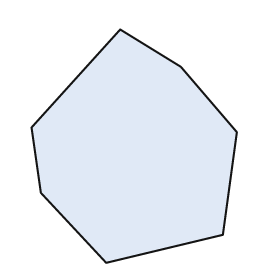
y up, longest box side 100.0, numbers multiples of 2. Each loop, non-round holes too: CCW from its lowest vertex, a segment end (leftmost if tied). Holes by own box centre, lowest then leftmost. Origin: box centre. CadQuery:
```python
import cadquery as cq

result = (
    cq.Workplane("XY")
    .moveTo(-12.0, -50.0)
    .lineTo(38.0, -38.0)
    .lineTo(44.0, 6.0)
    .lineTo(20.0, 34.0)
    .lineTo(-6.0, 50.0)
    .lineTo(-44.0, 8.0)
    .lineTo(-40.0, -20.0)
    .close()
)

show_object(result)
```